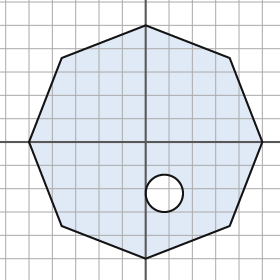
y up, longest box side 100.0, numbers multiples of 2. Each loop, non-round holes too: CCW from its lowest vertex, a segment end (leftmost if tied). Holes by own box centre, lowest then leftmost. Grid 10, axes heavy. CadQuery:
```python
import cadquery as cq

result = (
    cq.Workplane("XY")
    .moveTo(0.0, -50.0)
    .lineTo(36.0, -36.0)
    .lineTo(50.0, 0.0)
    .lineTo(36.0, 36.0)
    .lineTo(0.0, 50.0)
    .lineTo(-36.0, 36.0)
    .lineTo(-50.0, 0.0)
    .lineTo(-36.0, -36.0)
    .close()
    .moveTo(8.0, -22.0)
    .circle(8.0)
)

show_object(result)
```